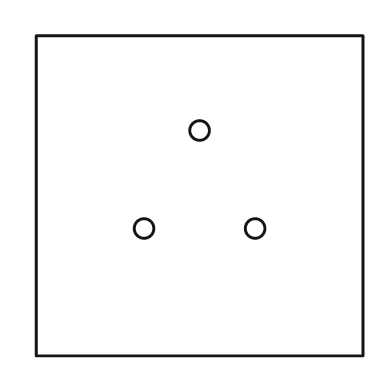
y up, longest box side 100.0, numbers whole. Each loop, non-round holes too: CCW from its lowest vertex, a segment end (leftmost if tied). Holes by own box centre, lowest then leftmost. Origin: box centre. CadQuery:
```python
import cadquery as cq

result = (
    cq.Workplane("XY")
    .moveTo(-50.0, -49.0)
    .lineTo(50.0, -49.0)
    .lineTo(50.0, 49.0)
    .lineTo(-50.0, 49.0)
    .close()
    .moveTo(-17.0, -10.0)
    .circle(3.0)
    .moveTo(17.0, -10.0)
    .circle(3.0)
    .moveTo(0.0, 20.0)
    .circle(3.0)
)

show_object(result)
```